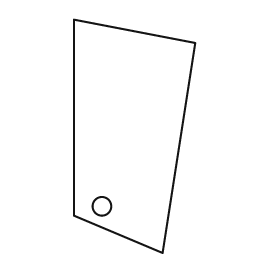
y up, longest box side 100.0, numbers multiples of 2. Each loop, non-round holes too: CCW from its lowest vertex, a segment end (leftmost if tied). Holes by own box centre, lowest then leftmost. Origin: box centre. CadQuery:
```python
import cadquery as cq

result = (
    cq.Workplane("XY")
    .moveTo(12.0, -50.0)
    .lineTo(26.0, 40.0)
    .lineTo(-26.0, 50.0)
    .lineTo(-26.0, -34.0)
    .close()
    .moveTo(-14.0, -30.0)
    .circle(4.0)
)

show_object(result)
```